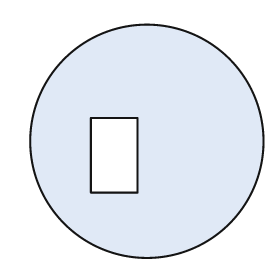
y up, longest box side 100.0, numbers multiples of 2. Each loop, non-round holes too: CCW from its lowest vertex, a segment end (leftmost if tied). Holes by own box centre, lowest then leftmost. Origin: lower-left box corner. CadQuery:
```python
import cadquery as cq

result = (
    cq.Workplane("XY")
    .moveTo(50.0, 50.0)
    .circle(50.0)
    .moveTo(26.0, 28.0)
    .lineTo(46.0, 28.0)
    .lineTo(46.0, 60.0)
    .lineTo(26.0, 60.0)
    .close()
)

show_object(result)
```